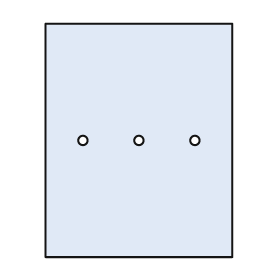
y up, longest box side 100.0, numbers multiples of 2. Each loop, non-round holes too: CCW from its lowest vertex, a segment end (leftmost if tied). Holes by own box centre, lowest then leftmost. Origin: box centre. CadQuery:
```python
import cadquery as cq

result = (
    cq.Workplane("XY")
    .moveTo(-40.0, -50.0)
    .lineTo(40.0, -50.0)
    .lineTo(40.0, 50.0)
    .lineTo(-40.0, 50.0)
    .close()
    .moveTo(-24.0, 0.0)
    .circle(2.0)
    .moveTo(0.0, 0.0)
    .circle(2.0)
    .moveTo(24.0, 0.0)
    .circle(2.0)
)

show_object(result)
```